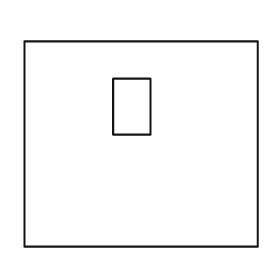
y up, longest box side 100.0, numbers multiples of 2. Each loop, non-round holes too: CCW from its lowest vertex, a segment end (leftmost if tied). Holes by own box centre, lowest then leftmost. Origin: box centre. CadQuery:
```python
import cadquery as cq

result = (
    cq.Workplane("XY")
    .moveTo(-50.0, -44.0)
    .lineTo(50.0, -44.0)
    .lineTo(50.0, 44.0)
    .lineTo(-50.0, 44.0)
    .close()
    .moveTo(-12.0, 4.0)
    .lineTo(4.0, 4.0)
    .lineTo(4.0, 28.0)
    .lineTo(-12.0, 28.0)
    .close()
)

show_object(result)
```